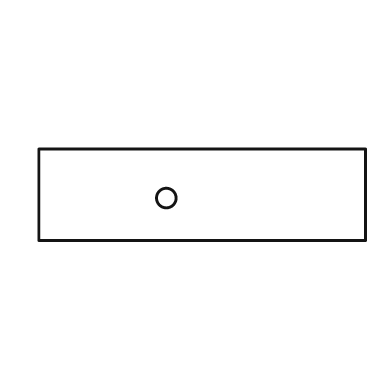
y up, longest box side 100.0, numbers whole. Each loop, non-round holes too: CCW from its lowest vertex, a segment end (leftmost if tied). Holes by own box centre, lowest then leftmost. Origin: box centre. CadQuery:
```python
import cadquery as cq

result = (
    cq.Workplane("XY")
    .moveTo(-50.0, -14.0)
    .lineTo(50.0, -14.0)
    .lineTo(50.0, 14.0)
    .lineTo(-50.0, 14.0)
    .close()
    .moveTo(-11.0, -1.0)
    .circle(3.0)
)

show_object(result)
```